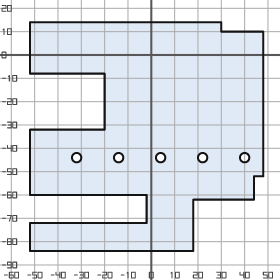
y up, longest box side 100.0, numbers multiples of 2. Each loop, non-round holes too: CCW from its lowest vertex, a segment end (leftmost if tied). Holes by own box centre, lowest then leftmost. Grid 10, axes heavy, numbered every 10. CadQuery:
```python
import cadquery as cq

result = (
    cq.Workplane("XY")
    .moveTo(-52.0, -84.0)
    .lineTo(18.0, -84.0)
    .lineTo(18.0, -62.0)
    .lineTo(44.0, -62.0)
    .lineTo(44.0, -52.0)
    .lineTo(48.0, -52.0)
    .lineTo(48.0, 10.0)
    .lineTo(30.0, 10.0)
    .lineTo(30.0, 14.0)
    .lineTo(-52.0, 14.0)
    .lineTo(-52.0, -8.0)
    .lineTo(-20.0, -8.0)
    .lineTo(-20.0, -32.0)
    .lineTo(-52.0, -32.0)
    .lineTo(-52.0, -60.0)
    .lineTo(-2.0, -60.0)
    .lineTo(-2.0, -72.0)
    .lineTo(-52.0, -72.0)
    .close()
    .moveTo(-32.0, -44.0)
    .circle(2.0)
    .moveTo(-14.0, -44.0)
    .circle(2.0)
    .moveTo(4.0, -44.0)
    .circle(2.0)
    .moveTo(22.0, -44.0)
    .circle(2.0)
    .moveTo(40.0, -44.0)
    .circle(2.0)
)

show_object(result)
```